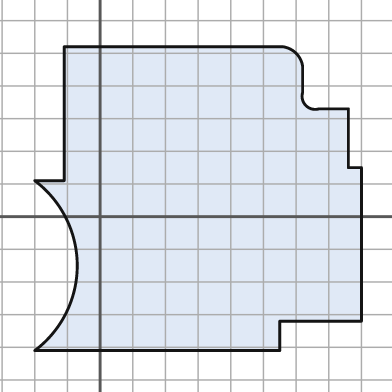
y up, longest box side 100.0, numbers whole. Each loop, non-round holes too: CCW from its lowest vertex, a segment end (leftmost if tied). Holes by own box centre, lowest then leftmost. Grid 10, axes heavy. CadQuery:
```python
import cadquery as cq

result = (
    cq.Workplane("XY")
    .moveTo(-20.0, -41.0)
    .lineTo(55.0, -41.0)
    .lineTo(55.0, -32.0)
    .lineTo(80.0, -32.0)
    .lineTo(80.0, 15.0)
    .lineTo(76.0, 15.0)
    .lineTo(76.0, 33.0)
    .lineTo(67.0, 33.0)
    .threePointArc((63.0, 34.0), (62.0, 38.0))
    .lineTo(62.0, 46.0)
    .threePointArc((60.0, 50.0), (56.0, 52.0))
    .lineTo(-11.0, 52.0)
    .lineTo(-11.0, 11.0)
    .lineTo(-20.0, 11.0)
    .threePointArc((-7.0, -15.0), (-20.0, -41.0))
    .close()
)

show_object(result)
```